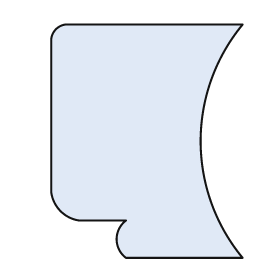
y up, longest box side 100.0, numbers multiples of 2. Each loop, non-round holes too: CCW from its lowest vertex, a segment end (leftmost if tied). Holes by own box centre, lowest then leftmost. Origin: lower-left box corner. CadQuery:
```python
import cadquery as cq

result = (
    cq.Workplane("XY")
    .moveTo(32.0, 0.0)
    .lineTo(82.0, 0.0)
    .threePointArc((64.0, 50.0), (82.0, 100.0))
    .lineTo(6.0, 100.0)
    .threePointArc((2.0, 98.0), (0.0, 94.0))
    .lineTo(0.0, 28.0)
    .threePointArc((4.0, 20.0), (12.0, 16.0))
    .lineTo(32.0, 16.0)
    .threePointArc((28.0, 8.0), (32.0, 0.0))
    .close()
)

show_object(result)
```